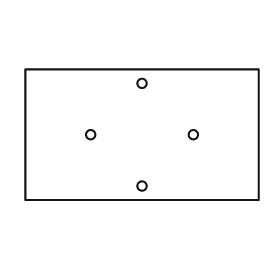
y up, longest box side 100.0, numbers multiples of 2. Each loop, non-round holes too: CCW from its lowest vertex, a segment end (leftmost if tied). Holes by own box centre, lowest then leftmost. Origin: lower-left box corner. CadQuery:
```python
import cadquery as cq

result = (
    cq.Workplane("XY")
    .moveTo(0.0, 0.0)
    .lineTo(100.0, 0.0)
    .lineTo(100.0, 56.0)
    .lineTo(0.0, 56.0)
    .close()
    .moveTo(50.0, 6.0)
    .circle(2.0)
    .moveTo(28.0, 28.0)
    .circle(2.0)
    .moveTo(72.0, 28.0)
    .circle(2.0)
    .moveTo(50.0, 50.0)
    .circle(2.0)
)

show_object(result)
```